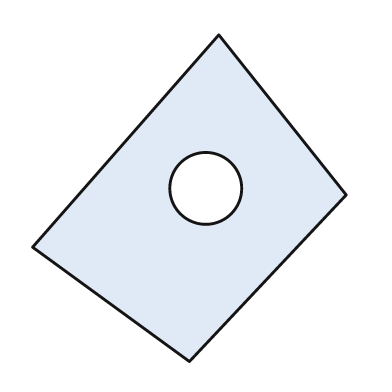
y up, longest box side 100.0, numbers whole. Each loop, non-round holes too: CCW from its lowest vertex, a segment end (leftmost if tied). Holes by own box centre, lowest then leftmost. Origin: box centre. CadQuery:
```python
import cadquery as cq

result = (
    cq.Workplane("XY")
    .moveTo(0.0, -50.0)
    .lineTo(48.0, 1.0)
    .lineTo(9.0, 50.0)
    .lineTo(-48.0, -15.0)
    .close()
    .moveTo(5.0, 3.0)
    .circle(11.0)
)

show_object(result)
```